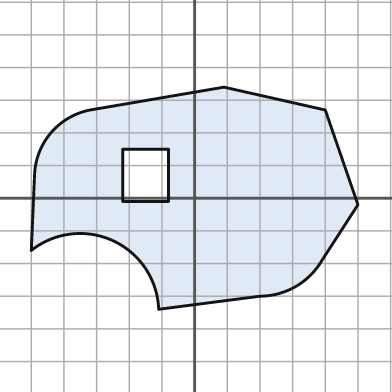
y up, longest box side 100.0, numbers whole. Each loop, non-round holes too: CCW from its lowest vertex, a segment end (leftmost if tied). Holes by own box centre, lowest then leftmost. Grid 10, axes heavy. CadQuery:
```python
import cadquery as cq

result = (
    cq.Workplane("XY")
    .moveTo(-11.0, -34.0)
    .lineTo(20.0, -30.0)
    .threePointArc((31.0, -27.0), (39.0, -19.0))
    .lineTo(50.0, -2.0)
    .lineTo(40.0, 27.0)
    .lineTo(9.0, 34.0)
    .lineTo(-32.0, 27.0)
    .threePointArc((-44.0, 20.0), (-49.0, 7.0))
    .lineTo(-50.0, -16.0)
    .threePointArc((-25.0, -13.0), (-11.0, -34.0))
    .close()
    .moveTo(-22.0, -1.0)
    .lineTo(-8.0, -1.0)
    .lineTo(-8.0, 15.0)
    .lineTo(-22.0, 15.0)
    .close()
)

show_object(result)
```